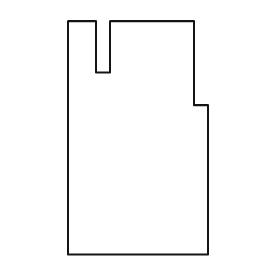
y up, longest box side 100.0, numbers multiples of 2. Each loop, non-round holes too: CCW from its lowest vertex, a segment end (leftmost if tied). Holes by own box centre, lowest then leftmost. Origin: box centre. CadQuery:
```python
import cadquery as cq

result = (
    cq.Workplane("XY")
    .moveTo(-30.0, -50.0)
    .lineTo(30.0, -50.0)
    .lineTo(30.0, 14.0)
    .lineTo(24.0, 14.0)
    .lineTo(24.0, 50.0)
    .lineTo(-12.0, 50.0)
    .lineTo(-12.0, 28.0)
    .lineTo(-18.0, 28.0)
    .lineTo(-18.0, 50.0)
    .lineTo(-30.0, 50.0)
    .close()
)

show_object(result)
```